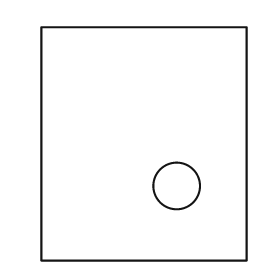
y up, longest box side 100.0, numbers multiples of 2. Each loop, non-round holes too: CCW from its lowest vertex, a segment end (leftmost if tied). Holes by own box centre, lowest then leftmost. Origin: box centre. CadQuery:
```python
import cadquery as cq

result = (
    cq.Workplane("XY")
    .moveTo(-44.0, -50.0)
    .lineTo(44.0, -50.0)
    .lineTo(44.0, 50.0)
    .lineTo(-44.0, 50.0)
    .close()
    .moveTo(14.0, -18.0)
    .circle(10.0)
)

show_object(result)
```